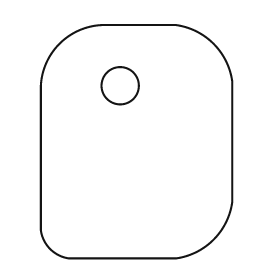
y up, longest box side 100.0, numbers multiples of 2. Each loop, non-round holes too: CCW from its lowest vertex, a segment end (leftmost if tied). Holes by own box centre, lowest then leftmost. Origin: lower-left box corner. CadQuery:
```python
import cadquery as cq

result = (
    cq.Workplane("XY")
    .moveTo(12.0, 0.0)
    .lineTo(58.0, 0.0)
    .threePointArc((74.0, 8.0), (82.0, 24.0))
    .lineTo(82.0, 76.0)
    .threePointArc((74.0, 92.0), (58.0, 100.0))
    .lineTo(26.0, 100.0)
    .threePointArc((8.0, 92.0), (0.0, 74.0))
    .lineTo(0.0, 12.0)
    .threePointArc((4.0, 4.0), (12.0, 0.0))
    .close()
    .moveTo(34.0, 74.0)
    .circle(8.0)
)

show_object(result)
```